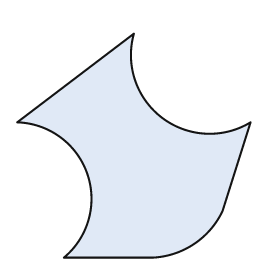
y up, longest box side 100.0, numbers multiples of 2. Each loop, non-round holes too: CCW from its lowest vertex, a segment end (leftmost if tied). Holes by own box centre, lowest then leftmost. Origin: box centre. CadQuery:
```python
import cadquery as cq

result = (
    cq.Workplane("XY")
    .moveTo(-30.0, -48.0)
    .lineTo(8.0, -48.0)
    .threePointArc((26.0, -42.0), (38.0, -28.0))
    .lineTo(50.0, 10.0)
    .threePointArc((12.0, 12.0), (0.0, 48.0))
    .lineTo(-50.0, 10.0)
    .threePointArc((-20.0, -12.0), (-30.0, -48.0))
    .close()
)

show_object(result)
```